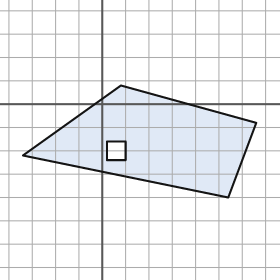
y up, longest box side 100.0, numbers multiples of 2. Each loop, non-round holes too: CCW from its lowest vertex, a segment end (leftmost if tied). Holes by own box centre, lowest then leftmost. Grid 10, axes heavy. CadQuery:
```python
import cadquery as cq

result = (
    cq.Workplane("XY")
    .moveTo(54.0, -40.0)
    .lineTo(66.0, -8.0)
    .lineTo(8.0, 8.0)
    .lineTo(-34.0, -22.0)
    .close()
    .moveTo(2.0, -24.0)
    .lineTo(10.0, -24.0)
    .lineTo(10.0, -16.0)
    .lineTo(2.0, -16.0)
    .close()
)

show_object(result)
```